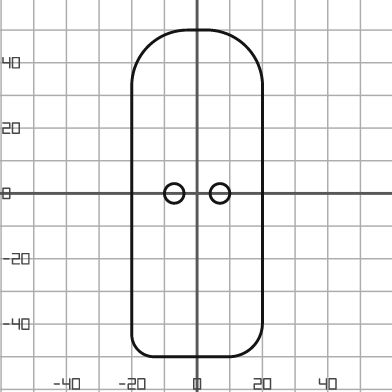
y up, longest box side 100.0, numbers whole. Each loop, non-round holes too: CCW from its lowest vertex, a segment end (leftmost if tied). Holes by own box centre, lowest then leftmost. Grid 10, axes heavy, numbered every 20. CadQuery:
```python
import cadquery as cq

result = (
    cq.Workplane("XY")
    .moveTo(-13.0, -50.0)
    .lineTo(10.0, -50.0)
    .threePointArc((17.0, -47.0), (20.0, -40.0))
    .lineTo(20.0, 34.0)
    .threePointArc((15.0, 45.0), (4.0, 50.0))
    .lineTo(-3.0, 50.0)
    .threePointArc((-15.0, 45.0), (-20.0, 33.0))
    .lineTo(-20.0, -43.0)
    .threePointArc((-18.0, -48.0), (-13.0, -50.0))
    .close()
    .moveTo(-7.0, 0.0)
    .circle(3.0)
    .moveTo(7.0, 0.0)
    .circle(3.0)
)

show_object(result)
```